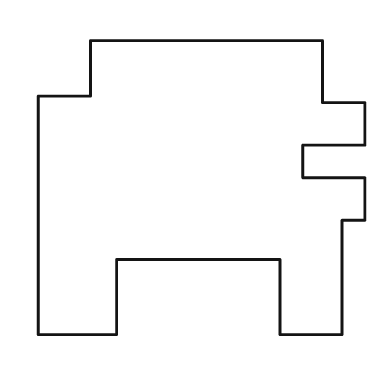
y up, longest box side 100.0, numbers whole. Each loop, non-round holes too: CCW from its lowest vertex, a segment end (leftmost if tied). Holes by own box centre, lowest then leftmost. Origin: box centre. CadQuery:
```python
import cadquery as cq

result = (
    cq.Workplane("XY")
    .moveTo(-50.0, -45.0)
    .lineTo(-26.0, -45.0)
    .lineTo(-26.0, -22.0)
    .lineTo(24.0, -22.0)
    .lineTo(24.0, -45.0)
    .lineTo(43.0, -45.0)
    .lineTo(43.0, -10.0)
    .lineTo(50.0, -10.0)
    .lineTo(50.0, 3.0)
    .lineTo(31.0, 3.0)
    .lineTo(31.0, 13.0)
    .lineTo(50.0, 13.0)
    .lineTo(50.0, 26.0)
    .lineTo(37.0, 26.0)
    .lineTo(37.0, 45.0)
    .lineTo(-34.0, 45.0)
    .lineTo(-34.0, 28.0)
    .lineTo(-50.0, 28.0)
    .close()
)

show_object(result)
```